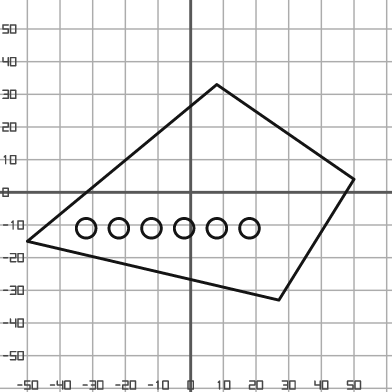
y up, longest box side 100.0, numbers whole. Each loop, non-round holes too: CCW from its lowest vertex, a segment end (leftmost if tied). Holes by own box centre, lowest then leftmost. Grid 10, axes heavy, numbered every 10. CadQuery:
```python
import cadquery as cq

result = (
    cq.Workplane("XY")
    .moveTo(27.0, -33.0)
    .lineTo(50.0, 4.0)
    .lineTo(8.0, 33.0)
    .lineTo(-50.0, -15.0)
    .close()
    .moveTo(-32.0, -11.0)
    .circle(3.0)
    .moveTo(-22.0, -11.0)
    .circle(3.0)
    .moveTo(-12.0, -11.0)
    .circle(3.0)
    .moveTo(-2.0, -11.0)
    .circle(3.0)
    .moveTo(8.0, -11.0)
    .circle(3.0)
    .moveTo(18.0, -11.0)
    .circle(3.0)
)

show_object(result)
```